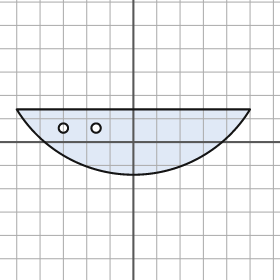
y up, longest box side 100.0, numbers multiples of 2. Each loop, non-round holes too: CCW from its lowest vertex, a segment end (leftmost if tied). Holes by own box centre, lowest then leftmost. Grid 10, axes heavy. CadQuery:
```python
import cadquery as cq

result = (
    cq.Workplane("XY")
    .moveTo(-50.0, 14.0)
    .threePointArc((0.0, -14.0), (50.0, 14.0))
    .close()
    .moveTo(-30.0, 6.0)
    .circle(2.0)
    .moveTo(-16.0, 6.0)
    .circle(2.0)
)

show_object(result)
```